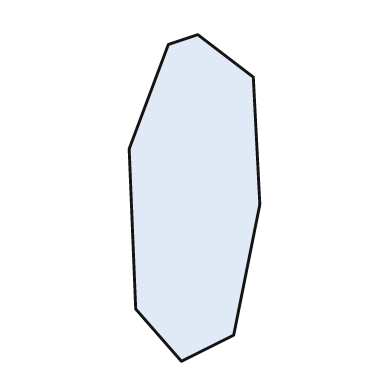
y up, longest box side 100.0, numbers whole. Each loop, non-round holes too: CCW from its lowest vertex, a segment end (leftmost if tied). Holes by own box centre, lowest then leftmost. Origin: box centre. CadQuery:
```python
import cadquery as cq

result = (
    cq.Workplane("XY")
    .moveTo(-4.0, -50.0)
    .lineTo(12.0, -42.0)
    .lineTo(20.0, -2.0)
    .lineTo(18.0, 37.0)
    .lineTo(1.0, 50.0)
    .lineTo(-8.0, 47.0)
    .lineTo(-20.0, 15.0)
    .lineTo(-18.0, -34.0)
    .close()
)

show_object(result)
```